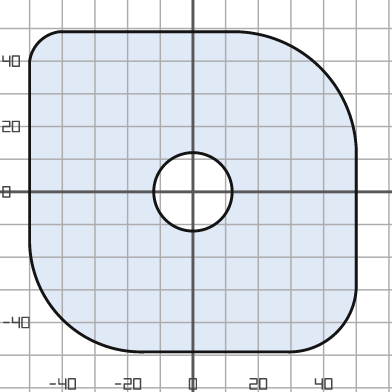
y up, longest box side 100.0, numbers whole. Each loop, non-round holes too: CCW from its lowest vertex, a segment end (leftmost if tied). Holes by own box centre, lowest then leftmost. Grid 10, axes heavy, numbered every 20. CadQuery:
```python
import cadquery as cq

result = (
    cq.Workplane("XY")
    .moveTo(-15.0, -49.0)
    .lineTo(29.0, -49.0)
    .threePointArc((44.0, -43.0), (50.0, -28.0))
    .lineTo(50.0, 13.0)
    .threePointArc((39.0, 38.0), (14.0, 49.0))
    .lineTo(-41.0, 49.0)
    .threePointArc((-47.0, 46.0), (-50.0, 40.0))
    .lineTo(-50.0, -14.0)
    .threePointArc((-40.0, -39.0), (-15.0, -49.0))
    .close()
    .moveTo(0.0, 0.0)
    .circle(12.0)
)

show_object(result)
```